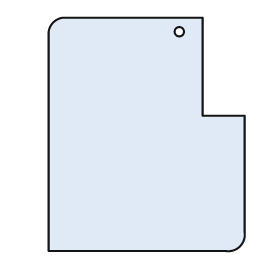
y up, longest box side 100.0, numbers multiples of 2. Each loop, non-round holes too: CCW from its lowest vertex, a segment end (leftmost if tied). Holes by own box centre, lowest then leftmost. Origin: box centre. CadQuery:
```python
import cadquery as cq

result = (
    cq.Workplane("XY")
    .moveTo(-42.0, -50.0)
    .lineTo(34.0, -50.0)
    .threePointArc((40.0, -48.0), (42.0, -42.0))
    .lineTo(42.0, 8.0)
    .lineTo(24.0, 8.0)
    .lineTo(24.0, 50.0)
    .lineTo(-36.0, 50.0)
    .threePointArc((-40.0, 48.0), (-42.0, 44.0))
    .close()
    .moveTo(14.0, 44.0)
    .circle(2.0)
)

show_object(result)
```